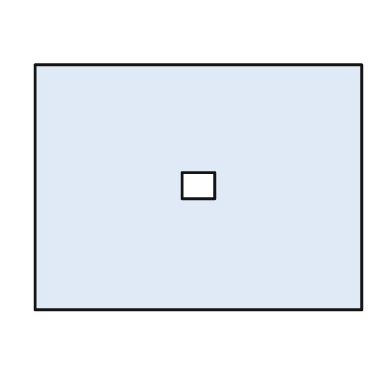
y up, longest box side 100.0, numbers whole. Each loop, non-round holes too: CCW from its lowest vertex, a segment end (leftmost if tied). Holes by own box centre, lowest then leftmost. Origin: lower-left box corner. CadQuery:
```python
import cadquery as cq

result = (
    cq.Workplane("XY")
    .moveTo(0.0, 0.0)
    .lineTo(100.0, 0.0)
    .lineTo(100.0, 75.0)
    .lineTo(0.0, 75.0)
    .close()
    .moveTo(45.0, 34.0)
    .lineTo(55.0, 34.0)
    .lineTo(55.0, 42.0)
    .lineTo(45.0, 42.0)
    .close()
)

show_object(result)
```